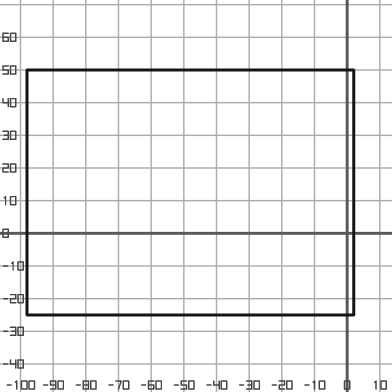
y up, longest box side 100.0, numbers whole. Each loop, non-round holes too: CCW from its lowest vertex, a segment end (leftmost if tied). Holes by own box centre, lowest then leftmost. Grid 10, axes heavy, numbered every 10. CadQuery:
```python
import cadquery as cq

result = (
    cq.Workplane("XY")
    .moveTo(-98.0, -25.0)
    .lineTo(2.0, -25.0)
    .lineTo(2.0, 50.0)
    .lineTo(-98.0, 50.0)
    .close()
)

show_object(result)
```